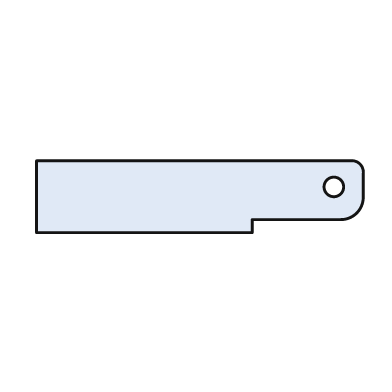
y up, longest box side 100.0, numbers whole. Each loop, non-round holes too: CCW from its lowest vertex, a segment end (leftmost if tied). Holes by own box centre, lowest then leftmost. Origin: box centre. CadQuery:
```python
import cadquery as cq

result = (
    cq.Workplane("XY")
    .moveTo(-50.0, -11.0)
    .lineTo(16.0, -11.0)
    .lineTo(16.0, -7.0)
    .lineTo(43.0, -7.0)
    .threePointArc((48.0, -5.0), (50.0, 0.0))
    .lineTo(50.0, 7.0)
    .threePointArc((49.0, 10.0), (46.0, 11.0))
    .lineTo(-50.0, 11.0)
    .close()
    .moveTo(41.0, 3.0)
    .circle(3.0)
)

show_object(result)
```